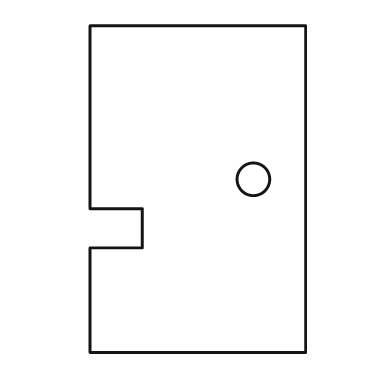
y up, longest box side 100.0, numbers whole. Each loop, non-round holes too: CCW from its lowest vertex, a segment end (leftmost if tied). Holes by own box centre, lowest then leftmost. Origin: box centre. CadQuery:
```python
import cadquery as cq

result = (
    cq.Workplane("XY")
    .moveTo(-33.0, -50.0)
    .lineTo(33.0, -50.0)
    .lineTo(33.0, 50.0)
    .lineTo(-33.0, 50.0)
    .lineTo(-33.0, -6.0)
    .lineTo(-17.0, -6.0)
    .lineTo(-17.0, -18.0)
    .lineTo(-33.0, -18.0)
    .close()
    .moveTo(17.0, 3.0)
    .circle(5.0)
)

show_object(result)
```